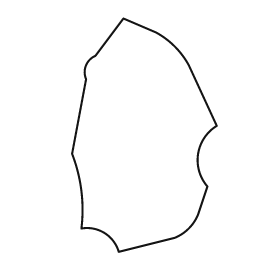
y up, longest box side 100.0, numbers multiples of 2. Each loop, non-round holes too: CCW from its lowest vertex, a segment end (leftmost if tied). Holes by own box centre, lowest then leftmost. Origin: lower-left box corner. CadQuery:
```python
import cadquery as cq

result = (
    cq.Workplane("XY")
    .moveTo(20.0, 0.0)
    .lineTo(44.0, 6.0)
    .threePointArc((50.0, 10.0), (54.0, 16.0))
    .lineTo(58.0, 28.0)
    .threePointArc((54.0, 42.0), (62.0, 54.0))
    .lineTo(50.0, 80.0)
    .threePointArc((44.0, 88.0), (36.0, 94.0))
    .lineTo(22.0, 100.0)
    .lineTo(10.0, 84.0)
    .threePointArc((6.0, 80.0), (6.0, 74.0))
    .lineTo(0.0, 42.0)
    .threePointArc((4.0, 26.0), (4.0, 10.0))
    .threePointArc((14.0, 8.0), (20.0, 0.0))
    .close()
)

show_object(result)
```